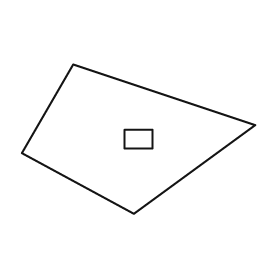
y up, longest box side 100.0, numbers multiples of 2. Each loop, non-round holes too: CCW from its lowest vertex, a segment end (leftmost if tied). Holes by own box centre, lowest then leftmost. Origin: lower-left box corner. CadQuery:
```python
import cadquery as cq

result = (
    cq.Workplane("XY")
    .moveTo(48.0, 0.0)
    .lineTo(100.0, 38.0)
    .lineTo(22.0, 64.0)
    .lineTo(0.0, 26.0)
    .close()
    .moveTo(44.0, 28.0)
    .lineTo(56.0, 28.0)
    .lineTo(56.0, 36.0)
    .lineTo(44.0, 36.0)
    .close()
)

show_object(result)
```